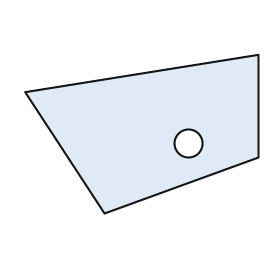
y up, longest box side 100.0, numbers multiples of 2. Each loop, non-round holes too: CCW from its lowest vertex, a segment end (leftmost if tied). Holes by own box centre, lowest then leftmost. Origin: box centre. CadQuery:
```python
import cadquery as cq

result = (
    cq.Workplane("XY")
    .moveTo(-16.0, -34.0)
    .lineTo(50.0, -10.0)
    .lineTo(50.0, 34.0)
    .lineTo(-50.0, 18.0)
    .close()
    .moveTo(20.0, -4.0)
    .circle(6.0)
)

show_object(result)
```